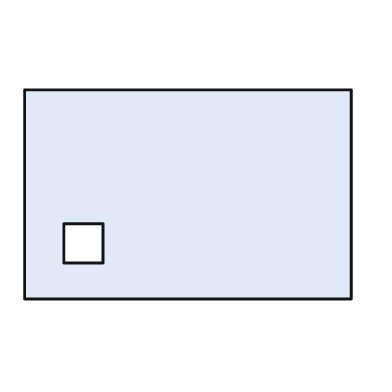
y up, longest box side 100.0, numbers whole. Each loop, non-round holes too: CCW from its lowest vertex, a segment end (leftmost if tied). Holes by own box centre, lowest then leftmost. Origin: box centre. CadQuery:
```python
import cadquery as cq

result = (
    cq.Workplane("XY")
    .moveTo(-50.0, -32.0)
    .lineTo(50.0, -32.0)
    .lineTo(50.0, 32.0)
    .lineTo(-50.0, 32.0)
    .close()
    .moveTo(-38.0, -21.0)
    .lineTo(-26.0, -21.0)
    .lineTo(-26.0, -9.0)
    .lineTo(-38.0, -9.0)
    .close()
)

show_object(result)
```